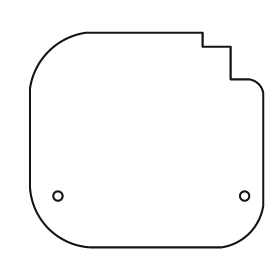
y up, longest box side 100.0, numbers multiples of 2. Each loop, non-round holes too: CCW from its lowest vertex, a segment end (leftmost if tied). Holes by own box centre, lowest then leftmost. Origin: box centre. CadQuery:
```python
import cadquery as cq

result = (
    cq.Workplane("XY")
    .moveTo(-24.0, -46.0)
    .lineTo(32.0, -46.0)
    .threePointArc((44.0, -40.0), (50.0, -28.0))
    .lineTo(50.0, 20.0)
    .threePointArc((48.0, 24.0), (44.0, 26.0))
    .lineTo(36.0, 26.0)
    .lineTo(36.0, 40.0)
    .lineTo(24.0, 40.0)
    .lineTo(24.0, 46.0)
    .lineTo(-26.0, 46.0)
    .threePointArc((-42.0, 38.0), (-50.0, 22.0))
    .lineTo(-50.0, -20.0)
    .threePointArc((-42.0, -38.0), (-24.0, -46.0))
    .close()
    .moveTo(-38.0, -24.0)
    .circle(2.0)
    .moveTo(42.0, -24.0)
    .circle(2.0)
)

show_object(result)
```